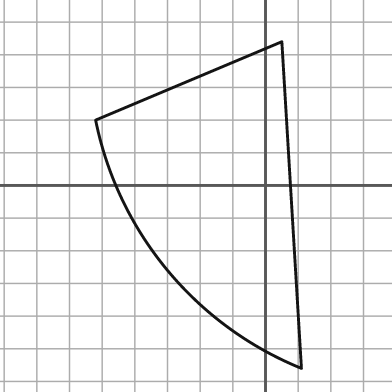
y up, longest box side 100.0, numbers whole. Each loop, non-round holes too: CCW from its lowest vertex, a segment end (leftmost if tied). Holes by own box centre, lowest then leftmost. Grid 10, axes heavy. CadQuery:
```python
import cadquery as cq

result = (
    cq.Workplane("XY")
    .moveTo(11.0, -56.0)
    .lineTo(5.0, 44.0)
    .lineTo(-52.0, 20.0)
    .threePointArc((-30.0, -26.0), (11.0, -56.0))
    .close()
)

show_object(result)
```